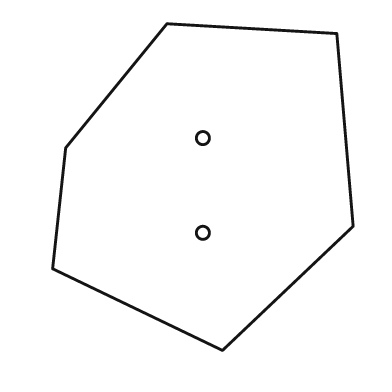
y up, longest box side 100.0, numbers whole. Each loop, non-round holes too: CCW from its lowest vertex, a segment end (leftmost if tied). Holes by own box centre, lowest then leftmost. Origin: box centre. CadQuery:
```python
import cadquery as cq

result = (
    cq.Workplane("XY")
    .moveTo(6.0, -50.0)
    .lineTo(46.0, -12.0)
    .lineTo(41.0, 47.0)
    .lineTo(-11.0, 50.0)
    .lineTo(-42.0, 12.0)
    .lineTo(-46.0, -25.0)
    .close()
    .moveTo(0.0, -14.0)
    .circle(2.0)
    .moveTo(0.0, 15.0)
    .circle(2.0)
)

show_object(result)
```